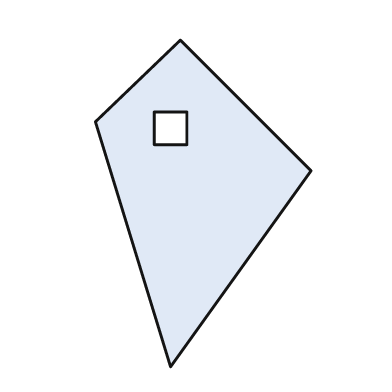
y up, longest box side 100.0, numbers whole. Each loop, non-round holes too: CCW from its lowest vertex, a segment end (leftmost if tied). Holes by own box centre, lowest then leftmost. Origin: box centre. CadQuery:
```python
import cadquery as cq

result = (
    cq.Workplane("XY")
    .moveTo(-10.0, -50.0)
    .lineTo(33.0, 10.0)
    .lineTo(-7.0, 50.0)
    .lineTo(-33.0, 25.0)
    .close()
    .moveTo(-15.0, 18.0)
    .lineTo(-5.0, 18.0)
    .lineTo(-5.0, 28.0)
    .lineTo(-15.0, 28.0)
    .close()
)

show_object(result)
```